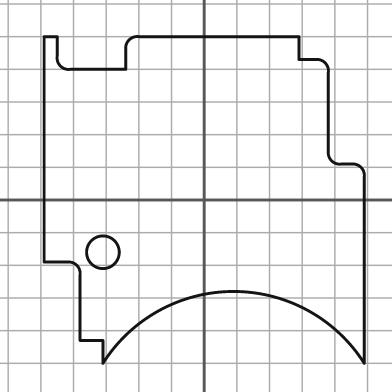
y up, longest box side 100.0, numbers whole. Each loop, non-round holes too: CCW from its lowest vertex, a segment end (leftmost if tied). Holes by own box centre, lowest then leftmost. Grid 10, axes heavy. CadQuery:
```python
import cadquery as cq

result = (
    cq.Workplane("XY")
    .moveTo(-31.0, -50.0)
    .threePointArc((9.0, -28.0), (49.0, -50.0))
    .lineTo(49.0, 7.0)
    .threePointArc((48.0, 10.0), (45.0, 11.0))
    .lineTo(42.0, 11.0)
    .threePointArc((39.0, 12.0), (38.0, 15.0))
    .lineTo(38.0, 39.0)
    .threePointArc((37.0, 42.0), (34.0, 43.0))
    .lineTo(29.0, 43.0)
    .lineTo(29.0, 50.0)
    .lineTo(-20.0, 50.0)
    .threePointArc((-23.0, 49.0), (-24.0, 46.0))
    .lineTo(-24.0, 40.0)
    .lineTo(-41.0, 40.0)
    .threePointArc((-44.0, 41.0), (-45.0, 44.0))
    .lineTo(-45.0, 50.0)
    .lineTo(-49.0, 50.0)
    .lineTo(-49.0, -19.0)
    .lineTo(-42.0, -19.0)
    .threePointArc((-39.0, -20.0), (-38.0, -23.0))
    .lineTo(-38.0, -43.0)
    .lineTo(-31.0, -43.0)
    .close()
    .moveTo(-31.0, -16.0)
    .circle(5.0)
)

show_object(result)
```